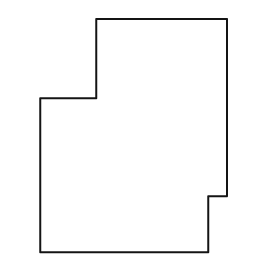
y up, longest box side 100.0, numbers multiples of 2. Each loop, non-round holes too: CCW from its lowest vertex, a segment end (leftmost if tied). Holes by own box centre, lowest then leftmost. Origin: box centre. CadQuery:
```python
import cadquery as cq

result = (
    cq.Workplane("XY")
    .moveTo(-40.0, -50.0)
    .lineTo(32.0, -50.0)
    .lineTo(32.0, -26.0)
    .lineTo(40.0, -26.0)
    .lineTo(40.0, 50.0)
    .lineTo(-16.0, 50.0)
    .lineTo(-16.0, 16.0)
    .lineTo(-40.0, 16.0)
    .close()
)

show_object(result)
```